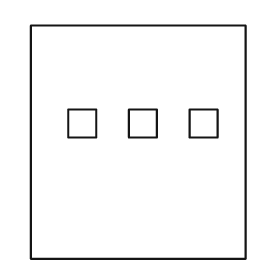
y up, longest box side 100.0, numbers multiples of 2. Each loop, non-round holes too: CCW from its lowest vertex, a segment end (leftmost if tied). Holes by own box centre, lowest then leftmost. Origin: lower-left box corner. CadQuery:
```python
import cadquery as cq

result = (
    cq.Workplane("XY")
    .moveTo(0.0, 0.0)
    .lineTo(92.0, 0.0)
    .lineTo(92.0, 100.0)
    .lineTo(0.0, 100.0)
    .close()
    .moveTo(16.0, 52.0)
    .lineTo(28.0, 52.0)
    .lineTo(28.0, 64.0)
    .lineTo(16.0, 64.0)
    .close()
    .moveTo(42.0, 52.0)
    .lineTo(54.0, 52.0)
    .lineTo(54.0, 64.0)
    .lineTo(42.0, 64.0)
    .close()
    .moveTo(68.0, 52.0)
    .lineTo(80.0, 52.0)
    .lineTo(80.0, 64.0)
    .lineTo(68.0, 64.0)
    .close()
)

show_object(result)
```